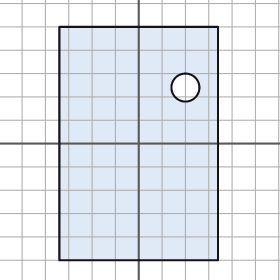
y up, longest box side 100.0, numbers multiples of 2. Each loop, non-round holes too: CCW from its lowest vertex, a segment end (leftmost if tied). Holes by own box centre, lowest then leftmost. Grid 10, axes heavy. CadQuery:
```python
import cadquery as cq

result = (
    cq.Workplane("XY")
    .moveTo(-34.0, -50.0)
    .lineTo(34.0, -50.0)
    .lineTo(34.0, 50.0)
    .lineTo(-34.0, 50.0)
    .close()
    .moveTo(20.0, 24.0)
    .circle(6.0)
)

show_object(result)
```